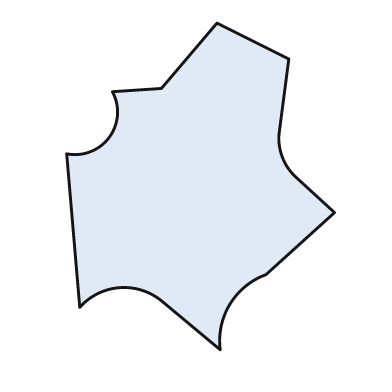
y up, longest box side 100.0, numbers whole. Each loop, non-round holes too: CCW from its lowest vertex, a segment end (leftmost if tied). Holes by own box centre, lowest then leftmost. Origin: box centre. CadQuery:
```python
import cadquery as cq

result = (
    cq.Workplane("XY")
    .moveTo(6.0, -50.0)
    .threePointArc((9.0, -36.0), (20.0, -27.0))
    .lineTo(41.0, -8.0)
    .lineTo(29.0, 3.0)
    .threePointArc((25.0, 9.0), (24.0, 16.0))
    .lineTo(27.0, 39.0)
    .lineTo(5.0, 50.0)
    .lineTo(-12.0, 30.0)
    .lineTo(-27.0, 29.0)
    .threePointArc((-28.0, 15.0), (-41.0, 10.0))
    .lineTo(-37.0, -37.0)
    .threePointArc((-25.0, -31.0), (-12.0, -35.0))
    .close()
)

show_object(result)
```